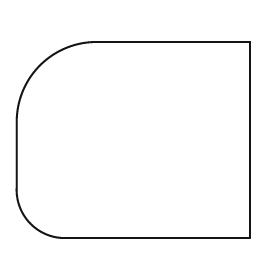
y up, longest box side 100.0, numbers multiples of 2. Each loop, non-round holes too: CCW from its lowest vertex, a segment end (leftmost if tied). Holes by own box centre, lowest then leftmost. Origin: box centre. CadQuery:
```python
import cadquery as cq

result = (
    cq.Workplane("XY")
    .moveTo(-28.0, -42.0)
    .lineTo(50.0, -42.0)
    .lineTo(50.0, 42.0)
    .lineTo(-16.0, 42.0)
    .threePointArc((-40.0, 32.0), (-50.0, 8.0))
    .lineTo(-50.0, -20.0)
    .threePointArc((-44.0, -36.0), (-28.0, -42.0))
    .close()
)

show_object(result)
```